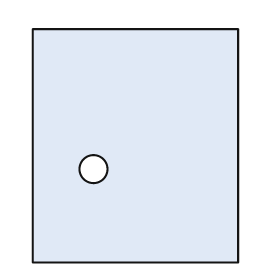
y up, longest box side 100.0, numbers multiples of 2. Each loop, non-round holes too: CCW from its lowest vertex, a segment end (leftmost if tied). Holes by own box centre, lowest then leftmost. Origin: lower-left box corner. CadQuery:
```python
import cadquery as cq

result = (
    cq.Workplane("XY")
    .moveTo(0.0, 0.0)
    .lineTo(88.0, 0.0)
    .lineTo(88.0, 100.0)
    .lineTo(0.0, 100.0)
    .close()
    .moveTo(26.0, 40.0)
    .circle(6.0)
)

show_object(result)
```